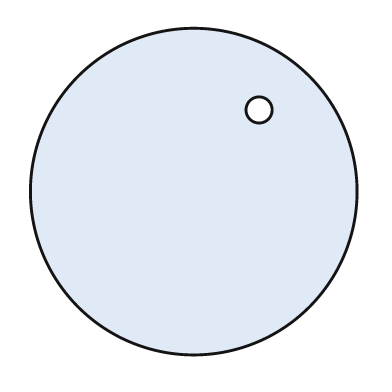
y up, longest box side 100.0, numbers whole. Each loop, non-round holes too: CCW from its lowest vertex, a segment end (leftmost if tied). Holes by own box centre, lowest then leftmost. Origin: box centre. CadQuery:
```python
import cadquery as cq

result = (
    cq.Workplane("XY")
    .moveTo(0.0, 0.0)
    .circle(50.0)
    .moveTo(20.0, 25.0)
    .circle(4.0)
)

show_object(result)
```